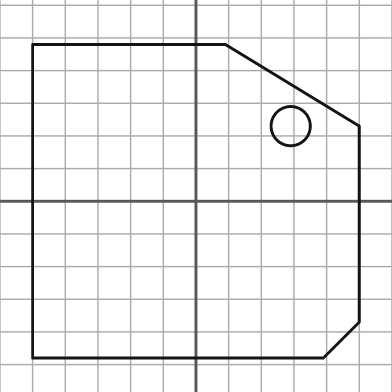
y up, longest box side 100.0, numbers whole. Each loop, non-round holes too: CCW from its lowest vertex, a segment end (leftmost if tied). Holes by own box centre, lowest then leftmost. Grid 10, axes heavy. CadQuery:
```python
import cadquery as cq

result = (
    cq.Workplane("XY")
    .moveTo(-50.0, -48.0)
    .lineTo(39.0, -48.0)
    .lineTo(50.0, -37.0)
    .lineTo(50.0, 23.0)
    .lineTo(9.0, 48.0)
    .lineTo(-50.0, 48.0)
    .close()
    .moveTo(29.0, 23.0)
    .circle(6.0)
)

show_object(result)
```